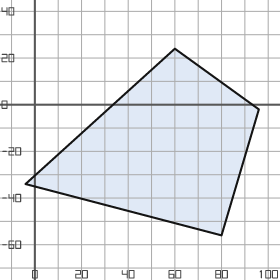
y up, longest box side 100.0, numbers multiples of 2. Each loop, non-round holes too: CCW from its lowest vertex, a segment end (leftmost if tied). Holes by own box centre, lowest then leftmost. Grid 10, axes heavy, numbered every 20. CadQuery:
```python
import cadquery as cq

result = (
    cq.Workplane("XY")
    .moveTo(80.0, -56.0)
    .lineTo(96.0, -2.0)
    .lineTo(60.0, 24.0)
    .lineTo(-4.0, -34.0)
    .close()
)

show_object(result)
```